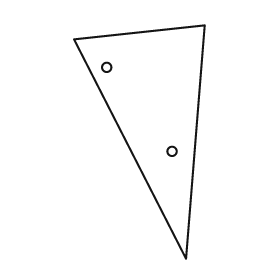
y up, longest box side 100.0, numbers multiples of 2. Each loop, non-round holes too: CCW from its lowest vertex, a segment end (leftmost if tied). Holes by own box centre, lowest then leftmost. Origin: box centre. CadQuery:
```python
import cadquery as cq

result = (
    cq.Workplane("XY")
    .moveTo(20.0, -50.0)
    .lineTo(28.0, 50.0)
    .lineTo(-28.0, 44.0)
    .close()
    .moveTo(14.0, -4.0)
    .circle(2.0)
    .moveTo(-14.0, 32.0)
    .circle(2.0)
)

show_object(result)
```